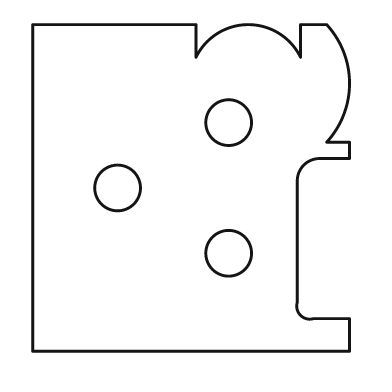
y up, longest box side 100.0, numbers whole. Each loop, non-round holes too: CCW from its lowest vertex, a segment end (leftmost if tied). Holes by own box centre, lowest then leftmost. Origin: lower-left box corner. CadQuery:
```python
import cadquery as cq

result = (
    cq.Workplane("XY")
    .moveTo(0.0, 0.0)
    .lineTo(97.0, 0.0)
    .lineTo(97.0, 10.0)
    .lineTo(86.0, 10.0)
    .threePointArc((82.0, 11.0), (81.0, 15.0))
    .lineTo(81.0, 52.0)
    .threePointArc((83.0, 57.0), (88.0, 59.0))
    .lineTo(97.0, 59.0)
    .lineTo(97.0, 64.0)
    .lineTo(90.0, 64.0)
    .threePointArc((97.0, 82.0), (90.0, 100.0))
    .lineTo(82.0, 100.0)
    .lineTo(82.0, 90.0)
    .threePointArc((66.0, 100.0), (50.0, 90.0))
    .lineTo(50.0, 100.0)
    .lineTo(0.0, 100.0)
    .close()
    .moveTo(60.0, 30.0)
    .circle(7.0)
    .moveTo(26.0, 50.0)
    .circle(7.0)
    .moveTo(60.0, 70.0)
    .circle(7.0)
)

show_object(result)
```